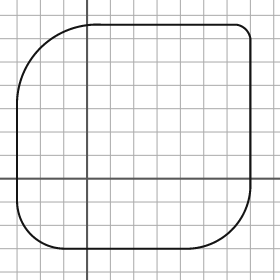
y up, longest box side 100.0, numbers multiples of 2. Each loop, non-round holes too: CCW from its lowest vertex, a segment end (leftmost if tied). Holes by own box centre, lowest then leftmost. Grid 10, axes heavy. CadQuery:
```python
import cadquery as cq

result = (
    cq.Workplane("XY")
    .moveTo(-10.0, -30.0)
    .lineTo(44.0, -30.0)
    .threePointArc((62.0, -22.0), (70.0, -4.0))
    .lineTo(70.0, 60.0)
    .threePointArc((68.0, 64.0), (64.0, 66.0))
    .lineTo(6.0, 66.0)
    .threePointArc((-20.0, 56.0), (-30.0, 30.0))
    .lineTo(-30.0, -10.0)
    .threePointArc((-24.0, -24.0), (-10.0, -30.0))
    .close()
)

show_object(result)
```